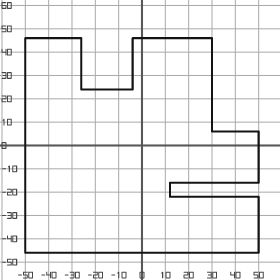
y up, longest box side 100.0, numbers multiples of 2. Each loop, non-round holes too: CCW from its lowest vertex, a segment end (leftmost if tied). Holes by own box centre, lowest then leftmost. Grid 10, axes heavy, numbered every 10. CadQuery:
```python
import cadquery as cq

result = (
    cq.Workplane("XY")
    .moveTo(-50.0, -46.0)
    .lineTo(50.0, -46.0)
    .lineTo(50.0, -22.0)
    .lineTo(12.0, -22.0)
    .lineTo(12.0, -16.0)
    .lineTo(50.0, -16.0)
    .lineTo(50.0, 6.0)
    .lineTo(30.0, 6.0)
    .lineTo(30.0, 46.0)
    .lineTo(-4.0, 46.0)
    .lineTo(-4.0, 24.0)
    .lineTo(-26.0, 24.0)
    .lineTo(-26.0, 46.0)
    .lineTo(-50.0, 46.0)
    .close()
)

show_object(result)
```